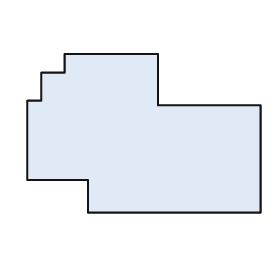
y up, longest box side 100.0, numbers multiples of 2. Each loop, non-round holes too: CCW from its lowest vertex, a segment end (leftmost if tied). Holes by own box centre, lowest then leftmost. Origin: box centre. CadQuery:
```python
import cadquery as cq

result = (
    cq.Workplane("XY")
    .moveTo(-24.0, -34.0)
    .lineTo(50.0, -34.0)
    .lineTo(50.0, 12.0)
    .lineTo(6.0, 12.0)
    .lineTo(6.0, 34.0)
    .lineTo(-34.0, 34.0)
    .lineTo(-34.0, 26.0)
    .lineTo(-44.0, 26.0)
    .lineTo(-44.0, 14.0)
    .lineTo(-50.0, 14.0)
    .lineTo(-50.0, -20.0)
    .lineTo(-24.0, -20.0)
    .close()
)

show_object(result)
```